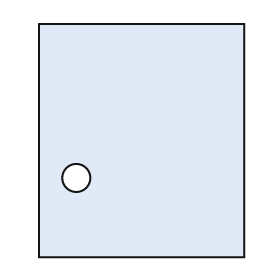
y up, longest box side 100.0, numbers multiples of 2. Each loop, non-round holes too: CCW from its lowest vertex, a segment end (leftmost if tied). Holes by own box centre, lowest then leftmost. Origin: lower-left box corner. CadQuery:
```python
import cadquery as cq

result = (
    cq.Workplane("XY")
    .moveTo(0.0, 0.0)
    .lineTo(88.0, 0.0)
    .lineTo(88.0, 100.0)
    .lineTo(0.0, 100.0)
    .close()
    .moveTo(16.0, 34.0)
    .circle(6.0)
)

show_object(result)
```